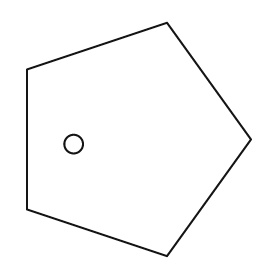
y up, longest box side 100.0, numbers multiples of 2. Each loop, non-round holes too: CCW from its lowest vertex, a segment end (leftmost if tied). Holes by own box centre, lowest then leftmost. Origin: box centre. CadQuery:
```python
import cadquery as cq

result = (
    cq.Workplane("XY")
    .moveTo(12.0, -50.0)
    .lineTo(48.0, 0.0)
    .lineTo(12.0, 50.0)
    .lineTo(-48.0, 30.0)
    .lineTo(-48.0, -30.0)
    .close()
    .moveTo(-28.0, -2.0)
    .circle(4.0)
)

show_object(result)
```